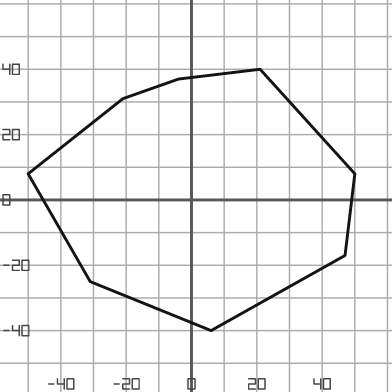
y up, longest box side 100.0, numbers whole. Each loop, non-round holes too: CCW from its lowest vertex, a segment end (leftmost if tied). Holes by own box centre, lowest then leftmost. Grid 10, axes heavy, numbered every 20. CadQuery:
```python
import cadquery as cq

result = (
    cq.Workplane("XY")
    .moveTo(6.0, -40.0)
    .lineTo(47.0, -17.0)
    .lineTo(50.0, 8.0)
    .lineTo(21.0, 40.0)
    .lineTo(-4.0, 37.0)
    .lineTo(-21.0, 31.0)
    .lineTo(-50.0, 8.0)
    .lineTo(-31.0, -25.0)
    .close()
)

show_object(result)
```